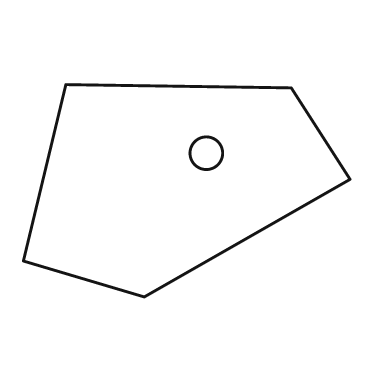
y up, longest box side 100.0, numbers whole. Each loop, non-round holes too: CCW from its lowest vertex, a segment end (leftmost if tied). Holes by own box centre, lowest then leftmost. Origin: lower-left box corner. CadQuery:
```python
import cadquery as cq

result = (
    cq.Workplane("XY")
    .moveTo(37.0, 0.0)
    .lineTo(100.0, 36.0)
    .lineTo(82.0, 64.0)
    .lineTo(13.0, 65.0)
    .lineTo(0.0, 11.0)
    .close()
    .moveTo(56.0, 44.0)
    .circle(5.0)
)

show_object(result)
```